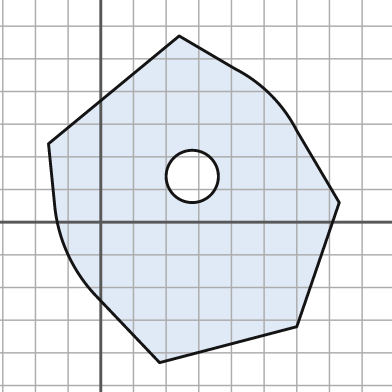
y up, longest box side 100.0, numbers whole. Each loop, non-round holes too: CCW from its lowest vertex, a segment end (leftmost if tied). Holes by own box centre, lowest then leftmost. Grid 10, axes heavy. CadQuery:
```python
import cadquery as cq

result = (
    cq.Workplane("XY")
    .moveTo(18.0, -43.0)
    .lineTo(60.0, -32.0)
    .lineTo(73.0, 6.0)
    .lineTo(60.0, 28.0)
    .threePointArc((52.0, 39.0), (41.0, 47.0))
    .lineTo(24.0, 57.0)
    .lineTo(-16.0, 24.0)
    .lineTo(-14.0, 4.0)
    .threePointArc((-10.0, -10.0), (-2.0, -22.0))
    .close()
    .moveTo(28.0, 14.0)
    .circle(8.0)
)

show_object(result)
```